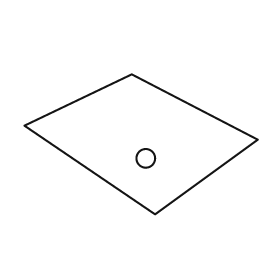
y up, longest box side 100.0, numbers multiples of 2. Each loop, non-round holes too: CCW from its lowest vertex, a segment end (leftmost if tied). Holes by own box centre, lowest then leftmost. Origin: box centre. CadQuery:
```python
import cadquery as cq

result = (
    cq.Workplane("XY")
    .moveTo(6.0, -30.0)
    .lineTo(50.0, 2.0)
    .lineTo(-4.0, 30.0)
    .lineTo(-50.0, 8.0)
    .close()
    .moveTo(2.0, -6.0)
    .circle(4.0)
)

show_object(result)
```